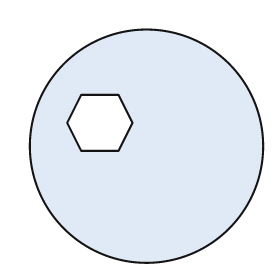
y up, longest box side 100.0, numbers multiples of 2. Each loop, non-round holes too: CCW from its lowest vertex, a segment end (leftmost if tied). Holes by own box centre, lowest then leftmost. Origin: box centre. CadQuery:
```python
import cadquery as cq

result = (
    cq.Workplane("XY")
    .moveTo(0.0, 0.0)
    .circle(50.0)
    .moveTo(-28.0, -2.0)
    .lineTo(-12.0, -2.0)
    .lineTo(-6.0, 10.0)
    .lineTo(-12.0, 22.0)
    .lineTo(-28.0, 22.0)
    .lineTo(-34.0, 10.0)
    .close()
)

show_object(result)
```